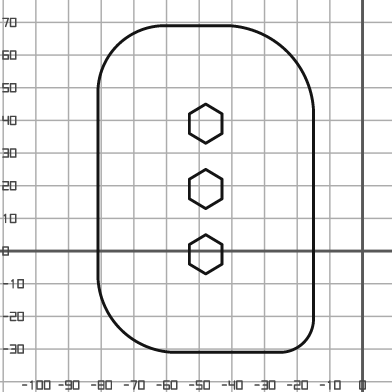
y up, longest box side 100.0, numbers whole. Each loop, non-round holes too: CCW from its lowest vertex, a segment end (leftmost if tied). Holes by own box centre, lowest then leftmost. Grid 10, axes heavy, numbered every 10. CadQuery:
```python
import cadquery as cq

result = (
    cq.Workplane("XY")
    .moveTo(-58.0, -31.0)
    .lineTo(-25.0, -31.0)
    .threePointArc((-18.0, -28.0), (-15.0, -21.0))
    .lineTo(-15.0, 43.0)
    .threePointArc((-23.0, 61.0), (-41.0, 69.0))
    .lineTo(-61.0, 69.0)
    .threePointArc((-75.0, 63.0), (-81.0, 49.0))
    .lineTo(-81.0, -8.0)
    .threePointArc((-74.0, -24.0), (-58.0, -31.0))
    .close()
    .moveTo(-48.0, -7.0)
    .lineTo(-43.0, -4.0)
    .lineTo(-43.0, 2.0)
    .lineTo(-48.0, 5.0)
    .lineTo(-53.0, 2.0)
    .lineTo(-53.0, -4.0)
    .close()
    .moveTo(-48.0, 13.0)
    .lineTo(-43.0, 16.0)
    .lineTo(-43.0, 22.0)
    .lineTo(-48.0, 25.0)
    .lineTo(-53.0, 22.0)
    .lineTo(-53.0, 16.0)
    .close()
    .moveTo(-48.0, 33.0)
    .lineTo(-43.0, 36.0)
    .lineTo(-43.0, 42.0)
    .lineTo(-48.0, 45.0)
    .lineTo(-53.0, 42.0)
    .lineTo(-53.0, 36.0)
    .close()
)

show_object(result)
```